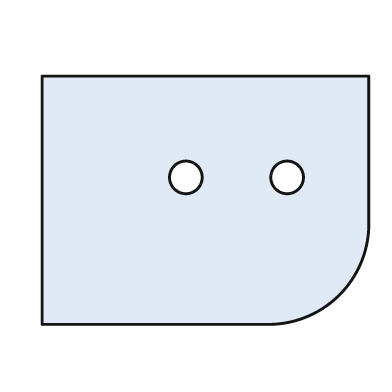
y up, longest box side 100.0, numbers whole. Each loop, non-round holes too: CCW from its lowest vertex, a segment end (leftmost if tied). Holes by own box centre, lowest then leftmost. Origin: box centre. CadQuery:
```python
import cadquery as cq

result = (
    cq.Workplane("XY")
    .moveTo(-50.0, -38.0)
    .lineTo(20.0, -38.0)
    .threePointArc((41.0, -29.0), (50.0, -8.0))
    .lineTo(50.0, 38.0)
    .lineTo(-50.0, 38.0)
    .close()
    .moveTo(-6.0, 7.0)
    .circle(5.0)
    .moveTo(25.0, 7.0)
    .circle(5.0)
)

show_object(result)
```